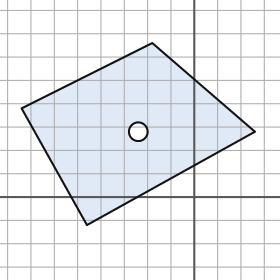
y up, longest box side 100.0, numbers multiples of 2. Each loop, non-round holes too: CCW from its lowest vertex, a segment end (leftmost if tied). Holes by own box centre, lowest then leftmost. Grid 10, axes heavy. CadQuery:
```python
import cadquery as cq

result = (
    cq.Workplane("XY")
    .moveTo(-46.0, -12.0)
    .lineTo(26.0, 28.0)
    .lineTo(-18.0, 66.0)
    .lineTo(-74.0, 38.0)
    .close()
    .moveTo(-24.0, 28.0)
    .circle(4.0)
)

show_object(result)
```